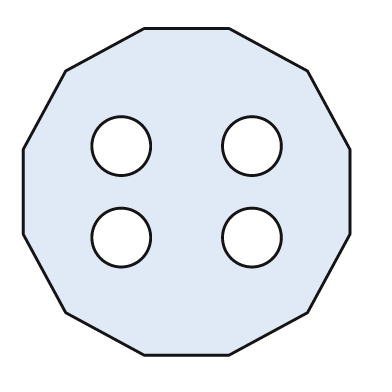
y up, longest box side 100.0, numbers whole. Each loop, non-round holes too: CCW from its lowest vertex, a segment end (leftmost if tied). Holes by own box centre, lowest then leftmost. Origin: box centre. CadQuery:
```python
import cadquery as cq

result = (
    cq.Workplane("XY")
    .moveTo(-13.0, -50.0)
    .lineTo(13.0, -50.0)
    .lineTo(37.0, -37.0)
    .lineTo(50.0, -13.0)
    .lineTo(50.0, 13.0)
    .lineTo(37.0, 37.0)
    .lineTo(13.0, 50.0)
    .lineTo(-13.0, 50.0)
    .lineTo(-37.0, 37.0)
    .lineTo(-50.0, 13.0)
    .lineTo(-50.0, -13.0)
    .lineTo(-37.0, -37.0)
    .close()
    .moveTo(-20.0, -14.0)
    .circle(9.0)
    .moveTo(20.0, -14.0)
    .circle(9.0)
    .moveTo(-20.0, 14.0)
    .circle(9.0)
    .moveTo(20.0, 14.0)
    .circle(9.0)
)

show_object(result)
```